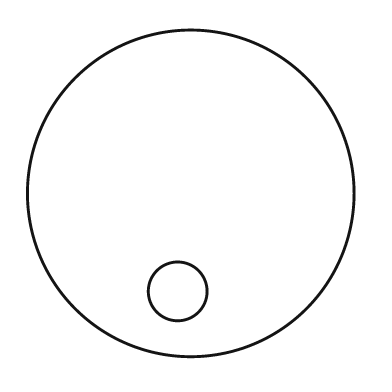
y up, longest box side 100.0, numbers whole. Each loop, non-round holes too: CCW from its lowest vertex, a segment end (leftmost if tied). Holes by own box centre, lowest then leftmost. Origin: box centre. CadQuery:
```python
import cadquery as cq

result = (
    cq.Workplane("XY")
    .moveTo(0.0, 0.0)
    .circle(50.0)
    .moveTo(-4.0, -30.0)
    .circle(9.0)
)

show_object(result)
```